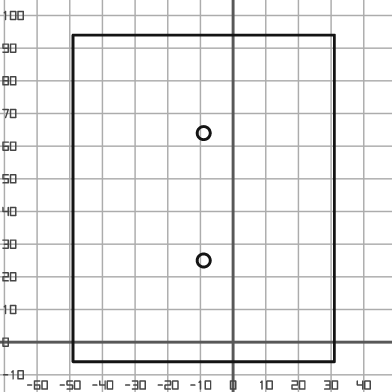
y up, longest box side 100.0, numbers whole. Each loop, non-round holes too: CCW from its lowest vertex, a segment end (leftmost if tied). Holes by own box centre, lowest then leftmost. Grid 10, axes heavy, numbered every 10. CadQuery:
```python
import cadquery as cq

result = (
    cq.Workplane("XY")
    .moveTo(-49.0, -6.0)
    .lineTo(31.0, -6.0)
    .lineTo(31.0, 94.0)
    .lineTo(-49.0, 94.0)
    .close()
    .moveTo(-9.0, 25.0)
    .circle(2.0)
    .moveTo(-9.0, 64.0)
    .circle(2.0)
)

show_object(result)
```